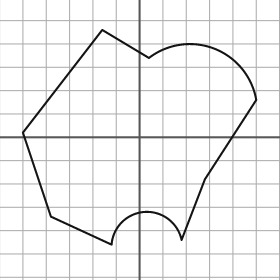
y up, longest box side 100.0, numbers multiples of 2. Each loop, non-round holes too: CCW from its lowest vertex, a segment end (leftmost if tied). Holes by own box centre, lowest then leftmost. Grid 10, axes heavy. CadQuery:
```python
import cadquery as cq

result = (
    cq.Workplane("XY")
    .moveTo(-12.0, -46.0)
    .threePointArc((2.0, -32.0), (18.0, -44.0))
    .lineTo(28.0, -18.0)
    .lineTo(50.0, 16.0)
    .threePointArc((32.0, 38.0), (4.0, 34.0))
    .lineTo(-16.0, 46.0)
    .lineTo(-50.0, 2.0)
    .lineTo(-38.0, -34.0)
    .close()
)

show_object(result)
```